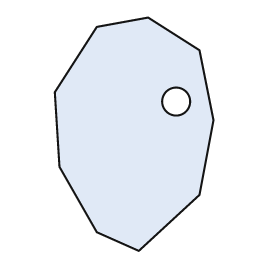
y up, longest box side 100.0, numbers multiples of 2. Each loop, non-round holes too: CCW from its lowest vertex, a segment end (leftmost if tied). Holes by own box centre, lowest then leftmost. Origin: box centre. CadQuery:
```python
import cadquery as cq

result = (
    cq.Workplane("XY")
    .moveTo(2.0, -50.0)
    .lineTo(28.0, -26.0)
    .lineTo(34.0, 6.0)
    .lineTo(28.0, 36.0)
    .lineTo(6.0, 50.0)
    .lineTo(-16.0, 46.0)
    .lineTo(-34.0, 18.0)
    .lineTo(-32.0, -14.0)
    .lineTo(-16.0, -42.0)
    .close()
    .moveTo(18.0, 14.0)
    .circle(6.0)
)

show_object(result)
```